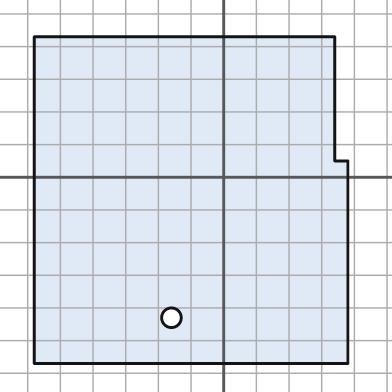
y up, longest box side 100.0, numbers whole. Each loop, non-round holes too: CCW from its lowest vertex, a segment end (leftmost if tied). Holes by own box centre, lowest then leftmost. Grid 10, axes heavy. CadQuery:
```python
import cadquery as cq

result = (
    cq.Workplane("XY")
    .moveTo(-58.0, -57.0)
    .lineTo(38.0, -57.0)
    .lineTo(38.0, 5.0)
    .lineTo(34.0, 5.0)
    .lineTo(34.0, 43.0)
    .lineTo(-58.0, 43.0)
    .close()
    .moveTo(-16.0, -43.0)
    .circle(3.0)
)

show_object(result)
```